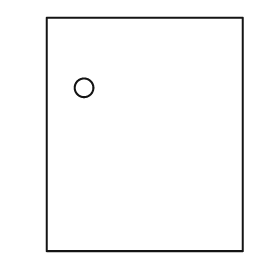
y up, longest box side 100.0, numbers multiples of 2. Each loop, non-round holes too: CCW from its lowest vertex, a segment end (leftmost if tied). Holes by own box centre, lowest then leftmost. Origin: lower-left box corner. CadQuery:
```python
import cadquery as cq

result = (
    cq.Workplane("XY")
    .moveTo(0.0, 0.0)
    .lineTo(84.0, 0.0)
    .lineTo(84.0, 100.0)
    .lineTo(0.0, 100.0)
    .close()
    .moveTo(16.0, 70.0)
    .circle(4.0)
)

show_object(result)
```